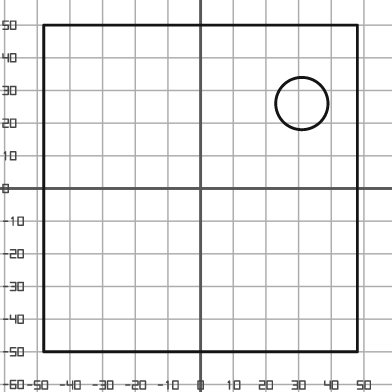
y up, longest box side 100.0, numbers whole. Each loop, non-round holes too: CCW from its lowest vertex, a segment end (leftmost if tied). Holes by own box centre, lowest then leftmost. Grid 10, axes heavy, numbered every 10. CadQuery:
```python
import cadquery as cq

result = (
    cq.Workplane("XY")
    .moveTo(-48.0, -50.0)
    .lineTo(48.0, -50.0)
    .lineTo(48.0, 50.0)
    .lineTo(-48.0, 50.0)
    .close()
    .moveTo(31.0, 26.0)
    .circle(8.0)
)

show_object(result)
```